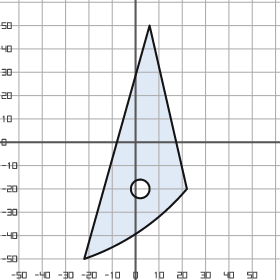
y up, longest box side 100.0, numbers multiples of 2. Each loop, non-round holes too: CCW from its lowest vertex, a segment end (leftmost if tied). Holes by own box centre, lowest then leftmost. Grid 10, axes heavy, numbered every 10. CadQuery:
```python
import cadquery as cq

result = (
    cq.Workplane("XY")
    .moveTo(-22.0, -50.0)
    .threePointArc((2.0, -38.0), (22.0, -20.0))
    .lineTo(6.0, 50.0)
    .close()
    .moveTo(2.0, -20.0)
    .circle(4.0)
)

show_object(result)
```